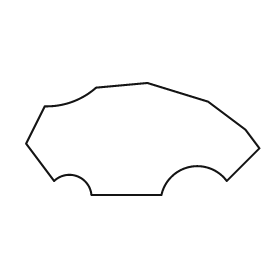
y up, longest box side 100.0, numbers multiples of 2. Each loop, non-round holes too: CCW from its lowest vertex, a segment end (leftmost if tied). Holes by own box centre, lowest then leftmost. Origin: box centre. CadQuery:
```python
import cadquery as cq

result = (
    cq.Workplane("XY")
    .moveTo(-22.0, -24.0)
    .lineTo(8.0, -24.0)
    .threePointArc((20.0, -12.0), (36.0, -18.0))
    .lineTo(50.0, -4.0)
    .lineTo(44.0, 4.0)
    .lineTo(28.0, 16.0)
    .lineTo(2.0, 24.0)
    .lineTo(-20.0, 22.0)
    .threePointArc((-30.0, 16.0), (-42.0, 14.0))
    .lineTo(-50.0, -2.0)
    .lineTo(-38.0, -18.0)
    .threePointArc((-28.0, -16.0), (-22.0, -24.0))
    .close()
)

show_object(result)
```